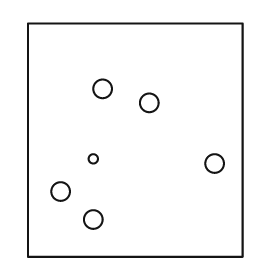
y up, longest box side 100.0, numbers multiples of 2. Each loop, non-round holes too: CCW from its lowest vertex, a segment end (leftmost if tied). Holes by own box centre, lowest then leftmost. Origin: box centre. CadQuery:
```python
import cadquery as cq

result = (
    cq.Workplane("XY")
    .moveTo(-46.0, -50.0)
    .lineTo(46.0, -50.0)
    .lineTo(46.0, 50.0)
    .lineTo(-46.0, 50.0)
    .close()
    .moveTo(-18.0, -34.0)
    .circle(4.0)
    .moveTo(-32.0, -22.0)
    .circle(4.0)
    .moveTo(34.0, -10.0)
    .circle(4.0)
    .moveTo(-18.0, -8.0)
    .circle(2.0)
    .moveTo(6.0, 16.0)
    .circle(4.0)
    .moveTo(-14.0, 22.0)
    .circle(4.0)
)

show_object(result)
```